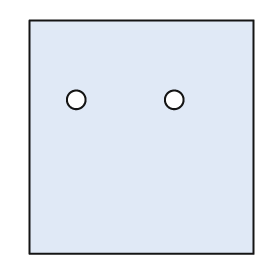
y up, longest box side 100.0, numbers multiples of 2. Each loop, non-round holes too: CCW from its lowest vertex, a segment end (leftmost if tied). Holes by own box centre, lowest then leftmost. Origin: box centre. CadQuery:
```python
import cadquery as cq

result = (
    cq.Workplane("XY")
    .moveTo(-48.0, -50.0)
    .lineTo(48.0, -50.0)
    .lineTo(48.0, 50.0)
    .lineTo(-48.0, 50.0)
    .close()
    .moveTo(-28.0, 16.0)
    .circle(4.0)
    .moveTo(14.0, 16.0)
    .circle(4.0)
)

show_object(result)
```